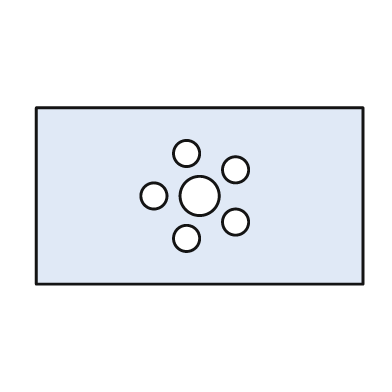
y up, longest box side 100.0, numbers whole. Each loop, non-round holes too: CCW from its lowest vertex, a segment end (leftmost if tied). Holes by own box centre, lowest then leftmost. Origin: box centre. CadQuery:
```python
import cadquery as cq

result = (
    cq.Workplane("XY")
    .moveTo(-50.0, -27.0)
    .lineTo(50.0, -27.0)
    .lineTo(50.0, 27.0)
    .lineTo(-50.0, 27.0)
    .close()
    .moveTo(-4.0, -13.0)
    .circle(4.0)
    .moveTo(11.0, -8.0)
    .circle(4.0)
    .moveTo(-14.0, 0.0)
    .circle(4.0)
    .moveTo(0.0, 0.0)
    .circle(6.0)
    .moveTo(11.0, 8.0)
    .circle(4.0)
    .moveTo(-4.0, 13.0)
    .circle(4.0)
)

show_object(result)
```